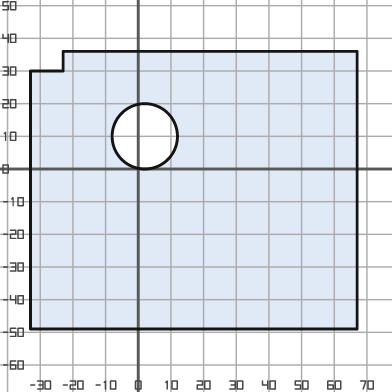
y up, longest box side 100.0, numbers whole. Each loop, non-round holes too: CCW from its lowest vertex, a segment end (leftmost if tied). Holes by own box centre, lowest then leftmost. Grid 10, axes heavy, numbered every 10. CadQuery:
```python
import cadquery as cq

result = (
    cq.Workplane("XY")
    .moveTo(-33.0, -49.0)
    .lineTo(67.0, -49.0)
    .lineTo(67.0, 36.0)
    .lineTo(-23.0, 36.0)
    .lineTo(-23.0, 30.0)
    .lineTo(-33.0, 30.0)
    .close()
    .moveTo(2.0, 10.0)
    .circle(10.0)
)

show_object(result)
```